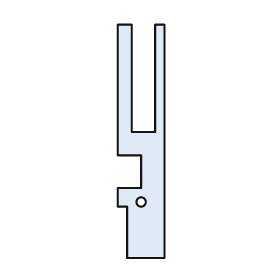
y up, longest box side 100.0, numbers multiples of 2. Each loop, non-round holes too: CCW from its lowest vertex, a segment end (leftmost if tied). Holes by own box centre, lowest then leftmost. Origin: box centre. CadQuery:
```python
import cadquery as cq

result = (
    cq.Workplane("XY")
    .moveTo(-6.0, -50.0)
    .lineTo(10.0, -50.0)
    .lineTo(10.0, 50.0)
    .lineTo(6.0, 50.0)
    .lineTo(6.0, 4.0)
    .lineTo(-4.0, 4.0)
    .lineTo(-4.0, 50.0)
    .lineTo(-10.0, 50.0)
    .lineTo(-10.0, -6.0)
    .lineTo(0.0, -6.0)
    .lineTo(0.0, -20.0)
    .lineTo(-10.0, -20.0)
    .lineTo(-10.0, -28.0)
    .lineTo(-6.0, -28.0)
    .close()
    .moveTo(0.0, -26.0)
    .circle(2.0)
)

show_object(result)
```